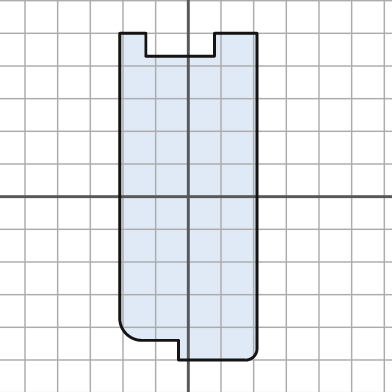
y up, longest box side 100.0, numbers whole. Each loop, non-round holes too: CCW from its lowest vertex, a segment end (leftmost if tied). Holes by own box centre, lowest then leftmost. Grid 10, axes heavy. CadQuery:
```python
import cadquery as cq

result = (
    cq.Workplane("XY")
    .moveTo(-3.0, -50.0)
    .lineTo(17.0, -50.0)
    .threePointArc((20.0, -49.0), (21.0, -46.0))
    .lineTo(21.0, 50.0)
    .lineTo(8.0, 50.0)
    .lineTo(8.0, 43.0)
    .lineTo(-13.0, 43.0)
    .lineTo(-13.0, 50.0)
    .lineTo(-21.0, 50.0)
    .lineTo(-21.0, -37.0)
    .threePointArc((-19.0, -42.0), (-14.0, -44.0))
    .lineTo(-3.0, -44.0)
    .close()
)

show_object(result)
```